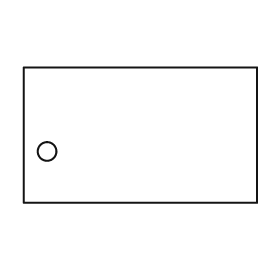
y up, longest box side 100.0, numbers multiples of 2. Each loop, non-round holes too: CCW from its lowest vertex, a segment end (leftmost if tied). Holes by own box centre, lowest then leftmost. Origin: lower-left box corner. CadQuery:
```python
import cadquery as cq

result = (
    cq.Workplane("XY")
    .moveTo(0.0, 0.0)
    .lineTo(100.0, 0.0)
    .lineTo(100.0, 58.0)
    .lineTo(0.0, 58.0)
    .close()
    .moveTo(10.0, 22.0)
    .circle(4.0)
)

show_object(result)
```